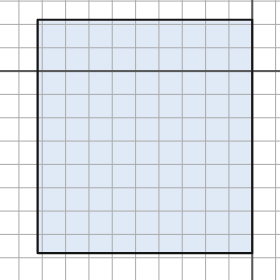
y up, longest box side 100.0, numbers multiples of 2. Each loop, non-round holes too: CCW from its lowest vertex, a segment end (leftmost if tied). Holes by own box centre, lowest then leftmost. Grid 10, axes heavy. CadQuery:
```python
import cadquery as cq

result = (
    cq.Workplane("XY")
    .moveTo(-92.0, -78.0)
    .lineTo(0.0, -78.0)
    .lineTo(0.0, 22.0)
    .lineTo(-92.0, 22.0)
    .close()
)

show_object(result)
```